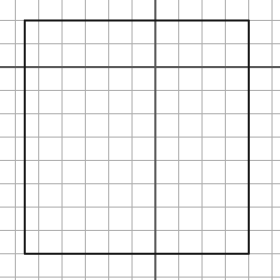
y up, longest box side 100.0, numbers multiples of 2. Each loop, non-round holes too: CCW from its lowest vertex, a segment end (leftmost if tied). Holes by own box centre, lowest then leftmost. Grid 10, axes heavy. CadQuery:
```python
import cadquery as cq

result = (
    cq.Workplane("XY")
    .moveTo(-56.0, -80.0)
    .lineTo(40.0, -80.0)
    .lineTo(40.0, 20.0)
    .lineTo(-56.0, 20.0)
    .close()
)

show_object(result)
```